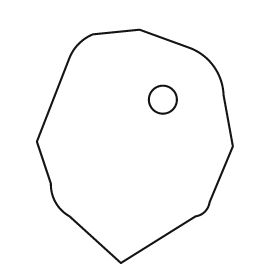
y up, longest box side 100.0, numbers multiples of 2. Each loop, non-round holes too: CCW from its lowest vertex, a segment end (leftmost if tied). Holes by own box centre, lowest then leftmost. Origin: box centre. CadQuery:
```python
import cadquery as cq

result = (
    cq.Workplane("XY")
    .moveTo(-6.0, -50.0)
    .lineTo(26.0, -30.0)
    .threePointArc((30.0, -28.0), (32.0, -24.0))
    .lineTo(42.0, 0.0)
    .lineTo(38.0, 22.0)
    .threePointArc((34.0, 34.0), (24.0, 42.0))
    .lineTo(2.0, 50.0)
    .lineTo(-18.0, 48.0)
    .threePointArc((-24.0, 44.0), (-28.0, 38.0))
    .lineTo(-42.0, 2.0)
    .lineTo(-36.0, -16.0)
    .threePointArc((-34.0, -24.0), (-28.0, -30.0))
    .close()
    .moveTo(12.0, 20.0)
    .circle(6.0)
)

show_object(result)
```